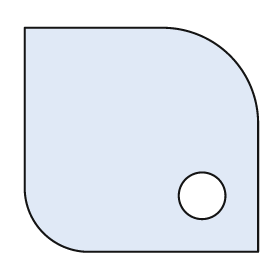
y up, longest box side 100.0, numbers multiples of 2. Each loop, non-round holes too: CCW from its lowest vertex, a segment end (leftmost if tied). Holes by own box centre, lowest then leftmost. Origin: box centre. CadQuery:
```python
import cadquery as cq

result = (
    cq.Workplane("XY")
    .moveTo(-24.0, -48.0)
    .lineTo(50.0, -48.0)
    .lineTo(50.0, 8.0)
    .threePointArc((38.0, 36.0), (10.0, 48.0))
    .lineTo(-50.0, 48.0)
    .lineTo(-50.0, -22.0)
    .threePointArc((-42.0, -40.0), (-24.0, -48.0))
    .close()
    .moveTo(26.0, -24.0)
    .circle(10.0)
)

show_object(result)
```